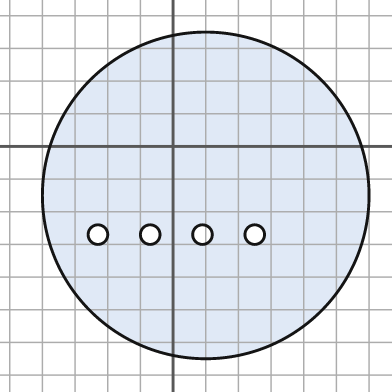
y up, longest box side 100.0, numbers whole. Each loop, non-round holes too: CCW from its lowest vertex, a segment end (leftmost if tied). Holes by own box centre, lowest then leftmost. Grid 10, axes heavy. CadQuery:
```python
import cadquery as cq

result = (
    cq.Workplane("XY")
    .moveTo(10.0, -15.0)
    .circle(50.0)
    .moveTo(-23.0, -27.0)
    .circle(3.0)
    .moveTo(-7.0, -27.0)
    .circle(3.0)
    .moveTo(9.0, -27.0)
    .circle(3.0)
    .moveTo(25.0, -27.0)
    .circle(3.0)
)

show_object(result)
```